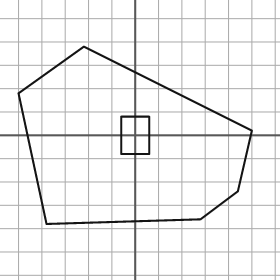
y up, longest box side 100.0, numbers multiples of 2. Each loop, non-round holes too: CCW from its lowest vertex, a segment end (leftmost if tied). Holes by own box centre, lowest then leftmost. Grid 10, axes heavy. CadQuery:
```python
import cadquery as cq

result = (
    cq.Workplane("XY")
    .moveTo(-38.0, -38.0)
    .lineTo(28.0, -36.0)
    .lineTo(44.0, -24.0)
    .lineTo(50.0, 2.0)
    .lineTo(-22.0, 38.0)
    .lineTo(-50.0, 18.0)
    .close()
    .moveTo(-6.0, -8.0)
    .lineTo(6.0, -8.0)
    .lineTo(6.0, 8.0)
    .lineTo(-6.0, 8.0)
    .close()
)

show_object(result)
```